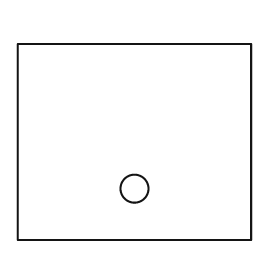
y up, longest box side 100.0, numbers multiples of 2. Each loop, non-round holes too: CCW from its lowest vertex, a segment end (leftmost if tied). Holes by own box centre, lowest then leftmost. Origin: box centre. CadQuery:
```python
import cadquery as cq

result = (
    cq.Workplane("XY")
    .moveTo(-50.0, -42.0)
    .lineTo(50.0, -42.0)
    .lineTo(50.0, 42.0)
    .lineTo(-50.0, 42.0)
    .close()
    .moveTo(0.0, -20.0)
    .circle(6.0)
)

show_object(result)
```